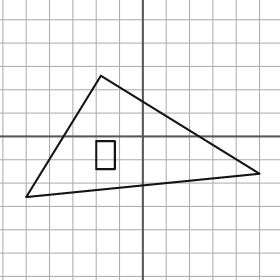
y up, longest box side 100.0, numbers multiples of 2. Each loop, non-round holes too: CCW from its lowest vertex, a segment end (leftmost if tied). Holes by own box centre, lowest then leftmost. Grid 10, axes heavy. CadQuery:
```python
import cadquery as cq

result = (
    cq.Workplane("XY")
    .moveTo(-50.0, -26.0)
    .lineTo(50.0, -16.0)
    .lineTo(-18.0, 26.0)
    .close()
    .moveTo(-20.0, -14.0)
    .lineTo(-12.0, -14.0)
    .lineTo(-12.0, -2.0)
    .lineTo(-20.0, -2.0)
    .close()
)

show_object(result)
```